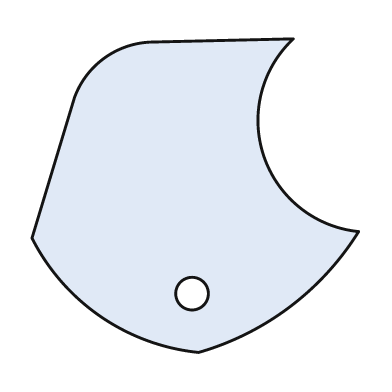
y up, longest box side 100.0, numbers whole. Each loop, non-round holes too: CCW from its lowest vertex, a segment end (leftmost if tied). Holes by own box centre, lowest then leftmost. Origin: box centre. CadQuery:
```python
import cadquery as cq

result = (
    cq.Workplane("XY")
    .moveTo(1.0, -48.0)
    .threePointArc((29.0, -34.0), (50.0, -11.0))
    .threePointArc((21.0, 12.0), (30.0, 48.0))
    .lineTo(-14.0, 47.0)
    .threePointArc((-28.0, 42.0), (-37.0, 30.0))
    .lineTo(-50.0, -13.0)
    .threePointArc((-29.0, -37.0), (1.0, -48.0))
    .close()
    .moveTo(-1.0, -30.0)
    .circle(5.0)
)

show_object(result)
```